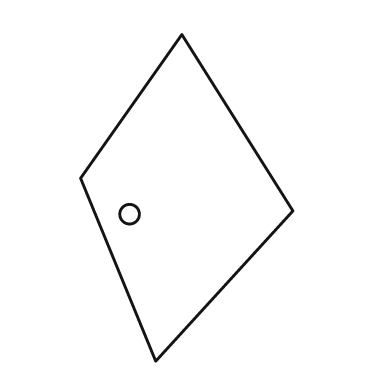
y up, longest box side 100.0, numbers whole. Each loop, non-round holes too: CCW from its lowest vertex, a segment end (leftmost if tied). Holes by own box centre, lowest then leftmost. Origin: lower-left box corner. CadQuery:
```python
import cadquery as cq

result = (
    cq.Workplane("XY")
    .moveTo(23.0, 0.0)
    .lineTo(65.0, 46.0)
    .lineTo(31.0, 100.0)
    .lineTo(0.0, 56.0)
    .close()
    .moveTo(15.0, 45.0)
    .circle(3.0)
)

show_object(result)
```